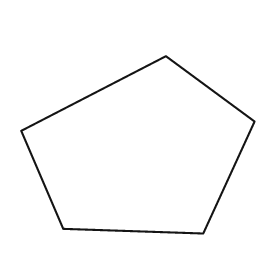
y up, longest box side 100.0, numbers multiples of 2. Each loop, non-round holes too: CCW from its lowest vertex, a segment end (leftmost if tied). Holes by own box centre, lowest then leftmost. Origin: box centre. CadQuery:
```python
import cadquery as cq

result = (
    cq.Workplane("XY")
    .moveTo(28.0, -38.0)
    .lineTo(50.0, 10.0)
    .lineTo(12.0, 38.0)
    .lineTo(-50.0, 6.0)
    .lineTo(-32.0, -36.0)
    .close()
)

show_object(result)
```